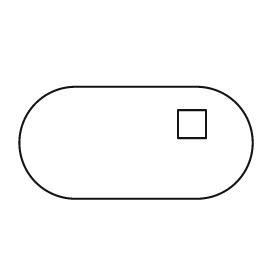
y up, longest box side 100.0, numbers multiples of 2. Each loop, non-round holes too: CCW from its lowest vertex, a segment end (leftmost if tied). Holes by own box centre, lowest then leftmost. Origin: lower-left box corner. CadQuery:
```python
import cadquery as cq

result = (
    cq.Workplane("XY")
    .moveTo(24.0, 0.0)
    .lineTo(76.0, 0.0)
    .threePointArc((100.0, 24.0), (76.0, 48.0))
    .lineTo(24.0, 48.0)
    .threePointArc((0.0, 24.0), (24.0, 0.0))
    .close()
    .moveTo(68.0, 26.0)
    .lineTo(80.0, 26.0)
    .lineTo(80.0, 38.0)
    .lineTo(68.0, 38.0)
    .close()
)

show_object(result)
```